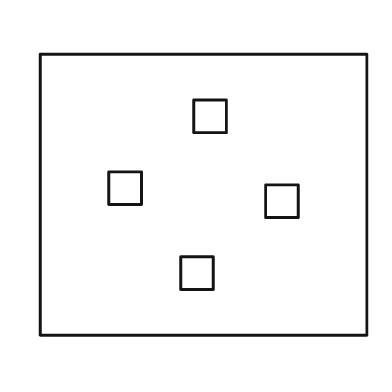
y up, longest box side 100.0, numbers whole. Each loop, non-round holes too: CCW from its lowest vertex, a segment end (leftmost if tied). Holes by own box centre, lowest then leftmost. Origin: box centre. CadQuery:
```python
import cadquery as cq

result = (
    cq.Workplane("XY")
    .moveTo(-50.0, -43.0)
    .lineTo(50.0, -43.0)
    .lineTo(50.0, 43.0)
    .lineTo(-50.0, 43.0)
    .close()
    .moveTo(-7.0, -29.0)
    .lineTo(3.0, -29.0)
    .lineTo(3.0, -19.0)
    .lineTo(-7.0, -19.0)
    .close()
    .moveTo(19.0, -7.0)
    .lineTo(29.0, -7.0)
    .lineTo(29.0, 3.0)
    .lineTo(19.0, 3.0)
    .close()
    .moveTo(-29.0, -3.0)
    .lineTo(-19.0, -3.0)
    .lineTo(-19.0, 7.0)
    .lineTo(-29.0, 7.0)
    .close()
    .moveTo(-3.0, 19.0)
    .lineTo(7.0, 19.0)
    .lineTo(7.0, 29.0)
    .lineTo(-3.0, 29.0)
    .close()
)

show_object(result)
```